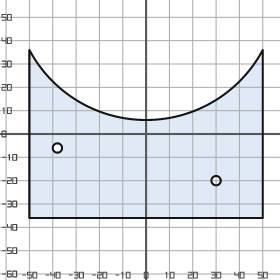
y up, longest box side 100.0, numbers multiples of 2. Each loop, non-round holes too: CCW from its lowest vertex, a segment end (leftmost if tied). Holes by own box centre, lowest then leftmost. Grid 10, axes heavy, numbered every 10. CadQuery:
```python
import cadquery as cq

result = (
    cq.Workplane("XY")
    .moveTo(-50.0, -36.0)
    .lineTo(50.0, -36.0)
    .lineTo(50.0, 36.0)
    .threePointArc((0.0, 6.0), (-50.0, 36.0))
    .close()
    .moveTo(30.0, -20.0)
    .circle(2.0)
    .moveTo(-38.0, -6.0)
    .circle(2.0)
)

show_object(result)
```